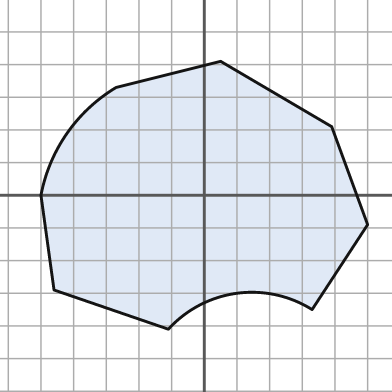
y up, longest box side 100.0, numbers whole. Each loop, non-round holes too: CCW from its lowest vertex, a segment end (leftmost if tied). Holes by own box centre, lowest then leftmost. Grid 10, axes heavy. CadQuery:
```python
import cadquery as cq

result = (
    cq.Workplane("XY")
    .moveTo(-11.0, -41.0)
    .threePointArc((10.0, -30.0), (33.0, -35.0))
    .lineTo(50.0, -9.0)
    .lineTo(39.0, 21.0)
    .lineTo(5.0, 41.0)
    .lineTo(-27.0, 33.0)
    .threePointArc((-42.0, 19.0), (-50.0, 0.0))
    .lineTo(-46.0, -29.0)
    .close()
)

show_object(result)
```